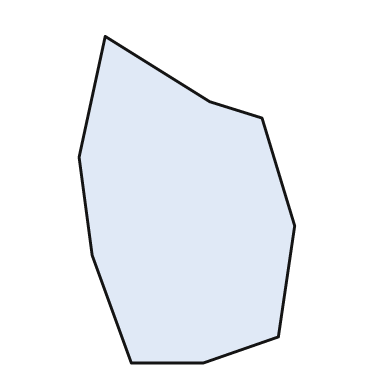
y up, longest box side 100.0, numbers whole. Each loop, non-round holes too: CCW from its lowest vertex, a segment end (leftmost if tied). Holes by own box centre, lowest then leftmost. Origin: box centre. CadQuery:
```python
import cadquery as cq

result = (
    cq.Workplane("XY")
    .moveTo(-17.0, -50.0)
    .lineTo(5.0, -50.0)
    .lineTo(28.0, -42.0)
    .lineTo(33.0, -8.0)
    .lineTo(23.0, 25.0)
    .lineTo(7.0, 30.0)
    .lineTo(-25.0, 50.0)
    .lineTo(-33.0, 13.0)
    .lineTo(-29.0, -17.0)
    .close()
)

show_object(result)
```